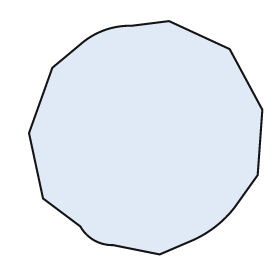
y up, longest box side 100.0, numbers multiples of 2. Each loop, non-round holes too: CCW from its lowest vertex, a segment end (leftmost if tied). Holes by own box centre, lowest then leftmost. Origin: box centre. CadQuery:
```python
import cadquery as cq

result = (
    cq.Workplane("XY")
    .moveTo(6.0, -50.0)
    .lineTo(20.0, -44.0)
    .threePointArc((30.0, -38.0), (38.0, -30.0))
    .lineTo(48.0, -16.0)
    .lineTo(50.0, 12.0)
    .lineTo(36.0, 38.0)
    .lineTo(10.0, 50.0)
    .lineTo(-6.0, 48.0)
    .threePointArc((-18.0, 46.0), (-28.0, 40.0))
    .lineTo(-40.0, 30.0)
    .lineTo(-50.0, 2.0)
    .lineTo(-44.0, -26.0)
    .lineTo(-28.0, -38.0)
    .threePointArc((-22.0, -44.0), (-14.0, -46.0))
    .close()
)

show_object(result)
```